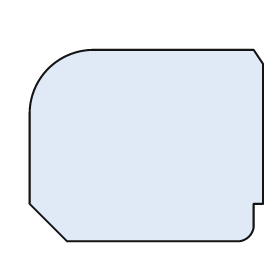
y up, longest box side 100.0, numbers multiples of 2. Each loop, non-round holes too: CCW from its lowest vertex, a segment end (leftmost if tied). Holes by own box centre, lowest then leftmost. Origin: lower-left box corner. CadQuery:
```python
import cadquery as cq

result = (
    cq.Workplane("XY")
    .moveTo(16.0, 0.0)
    .lineTo(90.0, 0.0)
    .threePointArc((94.0, 2.0), (96.0, 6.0))
    .lineTo(96.0, 16.0)
    .lineTo(100.0, 16.0)
    .lineTo(100.0, 76.0)
    .lineTo(96.0, 82.0)
    .lineTo(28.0, 82.0)
    .threePointArc((8.0, 74.0), (0.0, 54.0))
    .lineTo(0.0, 16.0)
    .close()
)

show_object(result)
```